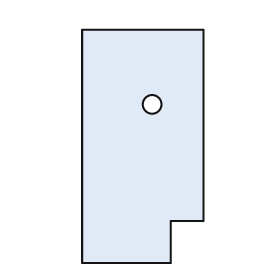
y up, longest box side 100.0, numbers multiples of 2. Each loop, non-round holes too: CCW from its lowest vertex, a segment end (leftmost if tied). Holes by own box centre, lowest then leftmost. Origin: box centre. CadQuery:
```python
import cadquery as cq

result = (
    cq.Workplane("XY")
    .moveTo(-26.0, -50.0)
    .lineTo(12.0, -50.0)
    .lineTo(12.0, -32.0)
    .lineTo(26.0, -32.0)
    .lineTo(26.0, 50.0)
    .lineTo(-26.0, 50.0)
    .close()
    .moveTo(4.0, 18.0)
    .circle(4.0)
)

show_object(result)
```